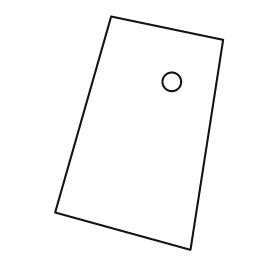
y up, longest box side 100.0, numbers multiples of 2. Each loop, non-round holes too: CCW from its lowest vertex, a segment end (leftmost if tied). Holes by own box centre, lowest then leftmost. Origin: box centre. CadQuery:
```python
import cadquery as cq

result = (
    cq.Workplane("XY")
    .moveTo(22.0, -50.0)
    .lineTo(36.0, 40.0)
    .lineTo(-12.0, 50.0)
    .lineTo(-36.0, -34.0)
    .close()
    .moveTo(14.0, 22.0)
    .circle(4.0)
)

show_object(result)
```